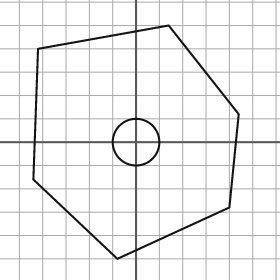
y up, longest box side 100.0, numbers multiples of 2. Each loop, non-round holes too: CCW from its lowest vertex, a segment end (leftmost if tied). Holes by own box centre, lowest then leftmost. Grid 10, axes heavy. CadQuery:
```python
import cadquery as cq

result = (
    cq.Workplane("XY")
    .moveTo(-8.0, -50.0)
    .lineTo(40.0, -28.0)
    .lineTo(44.0, 12.0)
    .lineTo(14.0, 50.0)
    .lineTo(-42.0, 40.0)
    .lineTo(-44.0, -16.0)
    .close()
    .moveTo(0.0, 0.0)
    .circle(10.0)
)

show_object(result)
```